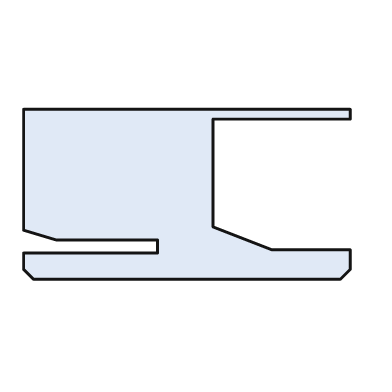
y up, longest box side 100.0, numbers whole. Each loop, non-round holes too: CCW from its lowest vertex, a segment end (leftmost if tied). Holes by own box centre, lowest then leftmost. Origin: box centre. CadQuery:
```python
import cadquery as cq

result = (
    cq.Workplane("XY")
    .moveTo(-47.0, -26.0)
    .lineTo(47.0, -26.0)
    .lineTo(50.0, -23.0)
    .lineTo(50.0, -17.0)
    .lineTo(26.0, -17.0)
    .lineTo(8.0, -10.0)
    .lineTo(8.0, 23.0)
    .lineTo(50.0, 23.0)
    .lineTo(50.0, 26.0)
    .lineTo(-50.0, 26.0)
    .lineTo(-50.0, -11.0)
    .lineTo(-40.0, -14.0)
    .lineTo(-9.0, -14.0)
    .lineTo(-9.0, -18.0)
    .lineTo(-50.0, -18.0)
    .lineTo(-50.0, -23.0)
    .close()
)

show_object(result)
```